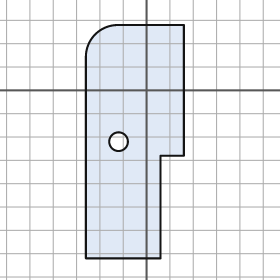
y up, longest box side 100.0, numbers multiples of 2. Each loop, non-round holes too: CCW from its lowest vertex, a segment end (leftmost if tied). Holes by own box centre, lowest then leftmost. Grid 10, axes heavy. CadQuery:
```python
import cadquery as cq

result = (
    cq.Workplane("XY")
    .moveTo(-26.0, -72.0)
    .lineTo(6.0, -72.0)
    .lineTo(6.0, -28.0)
    .lineTo(16.0, -28.0)
    .lineTo(16.0, 28.0)
    .lineTo(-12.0, 28.0)
    .threePointArc((-22.0, 24.0), (-26.0, 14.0))
    .close()
    .moveTo(-12.0, -22.0)
    .circle(4.0)
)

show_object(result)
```